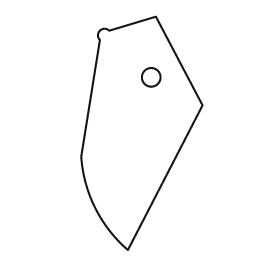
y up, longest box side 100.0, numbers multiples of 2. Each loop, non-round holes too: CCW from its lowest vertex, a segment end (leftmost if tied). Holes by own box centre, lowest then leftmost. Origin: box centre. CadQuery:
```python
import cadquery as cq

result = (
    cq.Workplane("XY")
    .moveTo(-6.0, -50.0)
    .lineTo(26.0, 12.0)
    .lineTo(6.0, 50.0)
    .lineTo(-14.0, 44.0)
    .threePointArc((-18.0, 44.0), (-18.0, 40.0))
    .lineTo(-26.0, -10.0)
    .threePointArc((-20.0, -32.0), (-6.0, -50.0))
    .close()
    .moveTo(4.0, 24.0)
    .circle(4.0)
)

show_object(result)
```